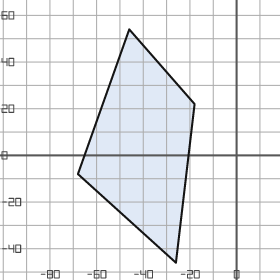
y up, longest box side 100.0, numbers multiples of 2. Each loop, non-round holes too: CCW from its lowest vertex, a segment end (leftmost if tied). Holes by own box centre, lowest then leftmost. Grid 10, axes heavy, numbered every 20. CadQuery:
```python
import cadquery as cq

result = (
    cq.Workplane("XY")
    .moveTo(-26.0, -46.0)
    .lineTo(-18.0, 22.0)
    .lineTo(-46.0, 54.0)
    .lineTo(-68.0, -8.0)
    .close()
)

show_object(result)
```